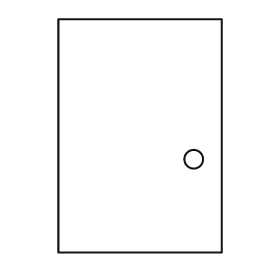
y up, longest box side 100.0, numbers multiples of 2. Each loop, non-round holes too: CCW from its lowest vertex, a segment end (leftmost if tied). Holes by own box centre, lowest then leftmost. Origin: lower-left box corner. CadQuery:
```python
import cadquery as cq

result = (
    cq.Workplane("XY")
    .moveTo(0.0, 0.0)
    .lineTo(70.0, 0.0)
    .lineTo(70.0, 100.0)
    .lineTo(0.0, 100.0)
    .close()
    .moveTo(58.0, 40.0)
    .circle(4.0)
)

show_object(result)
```